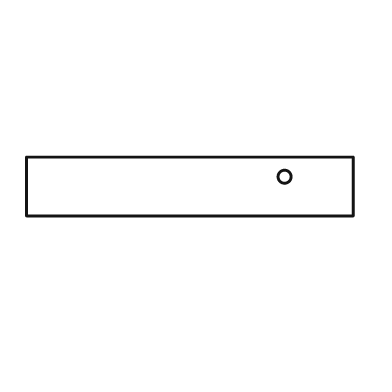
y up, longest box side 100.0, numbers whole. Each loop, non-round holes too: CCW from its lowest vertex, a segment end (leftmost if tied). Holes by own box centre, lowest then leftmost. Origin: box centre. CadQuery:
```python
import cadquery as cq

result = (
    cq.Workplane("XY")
    .moveTo(-50.0, -9.0)
    .lineTo(50.0, -9.0)
    .lineTo(50.0, 9.0)
    .lineTo(-50.0, 9.0)
    .close()
    .moveTo(29.0, 3.0)
    .circle(2.0)
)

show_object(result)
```